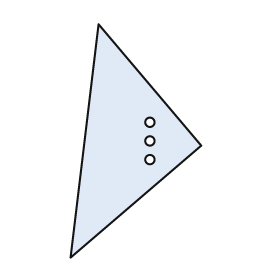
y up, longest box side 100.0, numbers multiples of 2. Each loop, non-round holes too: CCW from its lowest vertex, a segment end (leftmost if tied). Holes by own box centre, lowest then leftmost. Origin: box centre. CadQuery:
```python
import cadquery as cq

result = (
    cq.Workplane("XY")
    .moveTo(-28.0, -50.0)
    .lineTo(28.0, -2.0)
    .lineTo(-16.0, 50.0)
    .close()
    .moveTo(6.0, -8.0)
    .circle(2.0)
    .moveTo(6.0, 0.0)
    .circle(2.0)
    .moveTo(6.0, 8.0)
    .circle(2.0)
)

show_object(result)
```